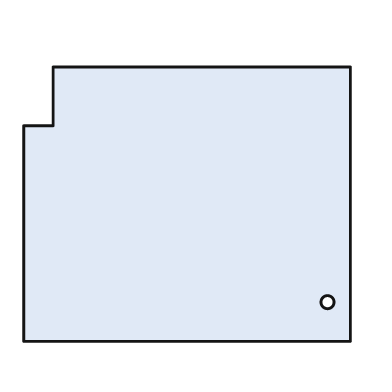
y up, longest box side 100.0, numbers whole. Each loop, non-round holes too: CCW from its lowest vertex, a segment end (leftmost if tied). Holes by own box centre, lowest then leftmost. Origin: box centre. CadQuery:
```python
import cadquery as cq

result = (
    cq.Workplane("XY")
    .moveTo(-50.0, -42.0)
    .lineTo(50.0, -42.0)
    .lineTo(50.0, 42.0)
    .lineTo(-41.0, 42.0)
    .lineTo(-41.0, 24.0)
    .lineTo(-50.0, 24.0)
    .close()
    .moveTo(43.0, -30.0)
    .circle(2.0)
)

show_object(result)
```